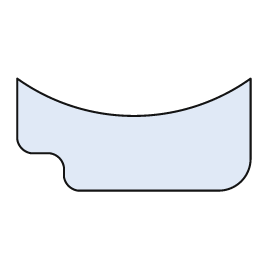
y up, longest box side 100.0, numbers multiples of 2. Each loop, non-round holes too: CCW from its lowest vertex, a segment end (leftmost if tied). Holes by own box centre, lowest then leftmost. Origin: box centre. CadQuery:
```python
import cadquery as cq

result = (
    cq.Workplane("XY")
    .moveTo(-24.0, -24.0)
    .lineTo(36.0, -24.0)
    .threePointArc((46.0, -20.0), (50.0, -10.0))
    .lineTo(50.0, 24.0)
    .threePointArc((0.0, 8.0), (-50.0, 24.0))
    .lineTo(-50.0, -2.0)
    .threePointArc((-48.0, -6.0), (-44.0, -8.0))
    .lineTo(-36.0, -8.0)
    .threePointArc((-32.0, -10.0), (-30.0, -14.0))
    .lineTo(-30.0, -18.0)
    .threePointArc((-28.0, -22.0), (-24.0, -24.0))
    .close()
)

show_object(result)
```